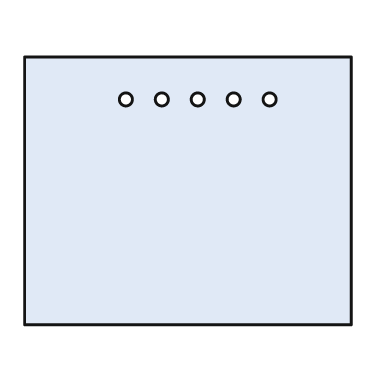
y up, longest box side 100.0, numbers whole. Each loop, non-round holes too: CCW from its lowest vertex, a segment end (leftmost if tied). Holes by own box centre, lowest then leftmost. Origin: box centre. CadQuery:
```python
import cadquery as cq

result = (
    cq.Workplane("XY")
    .moveTo(-50.0, -41.0)
    .lineTo(50.0, -41.0)
    .lineTo(50.0, 41.0)
    .lineTo(-50.0, 41.0)
    .close()
    .moveTo(-19.0, 28.0)
    .circle(2.0)
    .moveTo(-8.0, 28.0)
    .circle(2.0)
    .moveTo(3.0, 28.0)
    .circle(2.0)
    .moveTo(14.0, 28.0)
    .circle(2.0)
    .moveTo(25.0, 28.0)
    .circle(2.0)
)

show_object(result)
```